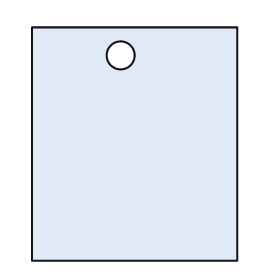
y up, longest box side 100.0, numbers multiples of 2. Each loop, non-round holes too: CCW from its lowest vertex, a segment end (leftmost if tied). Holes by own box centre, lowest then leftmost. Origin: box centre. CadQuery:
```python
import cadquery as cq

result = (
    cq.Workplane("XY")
    .moveTo(-44.0, -50.0)
    .lineTo(44.0, -50.0)
    .lineTo(44.0, 50.0)
    .lineTo(-44.0, 50.0)
    .close()
    .moveTo(-6.0, 38.0)
    .circle(6.0)
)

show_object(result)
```